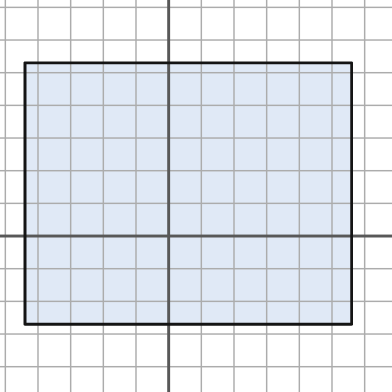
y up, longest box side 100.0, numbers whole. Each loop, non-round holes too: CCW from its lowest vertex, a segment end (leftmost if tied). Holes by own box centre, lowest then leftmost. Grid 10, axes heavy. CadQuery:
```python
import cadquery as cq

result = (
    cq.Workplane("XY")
    .moveTo(-44.0, -27.0)
    .lineTo(56.0, -27.0)
    .lineTo(56.0, 53.0)
    .lineTo(-44.0, 53.0)
    .close()
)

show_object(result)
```